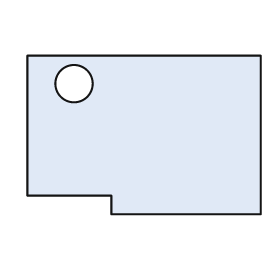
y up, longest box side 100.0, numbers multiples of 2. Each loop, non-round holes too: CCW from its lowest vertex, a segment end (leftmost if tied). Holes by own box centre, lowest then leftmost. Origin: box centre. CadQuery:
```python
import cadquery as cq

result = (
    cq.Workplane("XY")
    .moveTo(-14.0, -34.0)
    .lineTo(50.0, -34.0)
    .lineTo(50.0, 34.0)
    .lineTo(-50.0, 34.0)
    .lineTo(-50.0, -26.0)
    .lineTo(-14.0, -26.0)
    .close()
    .moveTo(-30.0, 22.0)
    .circle(8.0)
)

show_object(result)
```